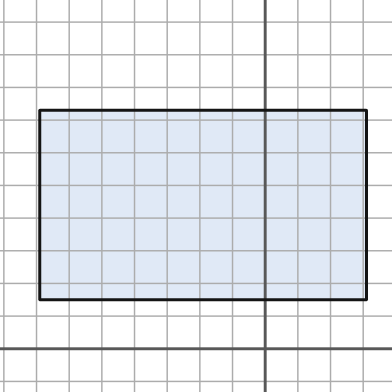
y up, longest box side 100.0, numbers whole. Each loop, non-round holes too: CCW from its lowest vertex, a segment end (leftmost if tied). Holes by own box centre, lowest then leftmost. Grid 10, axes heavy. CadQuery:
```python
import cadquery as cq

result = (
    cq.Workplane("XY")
    .moveTo(-69.0, 15.0)
    .lineTo(31.0, 15.0)
    .lineTo(31.0, 73.0)
    .lineTo(-69.0, 73.0)
    .close()
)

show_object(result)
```